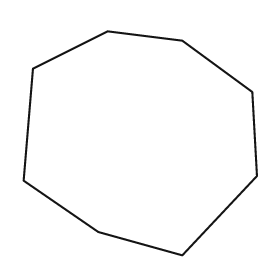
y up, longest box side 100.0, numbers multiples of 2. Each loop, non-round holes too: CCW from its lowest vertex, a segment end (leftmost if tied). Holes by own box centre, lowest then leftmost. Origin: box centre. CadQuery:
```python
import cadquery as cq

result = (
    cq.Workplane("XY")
    .moveTo(18.0, -48.0)
    .lineTo(50.0, -14.0)
    .lineTo(48.0, 22.0)
    .lineTo(18.0, 44.0)
    .lineTo(-14.0, 48.0)
    .lineTo(-46.0, 32.0)
    .lineTo(-50.0, -16.0)
    .lineTo(-18.0, -38.0)
    .close()
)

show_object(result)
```